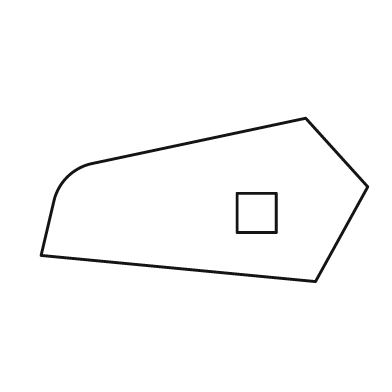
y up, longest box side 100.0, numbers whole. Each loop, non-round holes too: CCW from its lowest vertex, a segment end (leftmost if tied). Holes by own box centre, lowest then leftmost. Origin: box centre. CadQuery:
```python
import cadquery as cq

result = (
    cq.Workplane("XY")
    .moveTo(34.0, -25.0)
    .lineTo(50.0, 4.0)
    .lineTo(31.0, 25.0)
    .lineTo(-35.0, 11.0)
    .threePointArc((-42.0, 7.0), (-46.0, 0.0))
    .lineTo(-50.0, -17.0)
    .close()
    .moveTo(10.0, -10.0)
    .lineTo(22.0, -10.0)
    .lineTo(22.0, 2.0)
    .lineTo(10.0, 2.0)
    .close()
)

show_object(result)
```